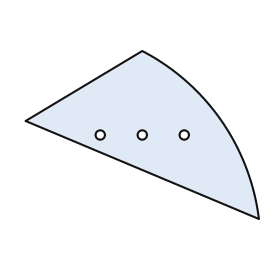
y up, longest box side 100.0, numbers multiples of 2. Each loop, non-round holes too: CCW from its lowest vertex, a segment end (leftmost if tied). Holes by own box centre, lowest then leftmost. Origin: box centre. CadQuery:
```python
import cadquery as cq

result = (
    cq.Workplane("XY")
    .moveTo(50.0, -36.0)
    .threePointArc((34.0, 6.0), (0.0, 36.0))
    .lineTo(-50.0, 6.0)
    .close()
    .moveTo(-18.0, 0.0)
    .circle(2.0)
    .moveTo(0.0, 0.0)
    .circle(2.0)
    .moveTo(18.0, 0.0)
    .circle(2.0)
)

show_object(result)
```